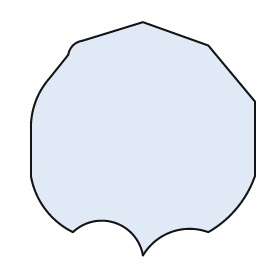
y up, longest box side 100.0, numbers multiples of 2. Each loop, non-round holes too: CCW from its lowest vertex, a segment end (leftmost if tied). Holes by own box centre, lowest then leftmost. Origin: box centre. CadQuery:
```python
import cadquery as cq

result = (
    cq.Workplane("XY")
    .moveTo(0.0, -50.0)
    .threePointArc((12.0, -40.0), (28.0, -40.0))
    .threePointArc((40.0, -30.0), (48.0, -16.0))
    .lineTo(48.0, 16.0)
    .lineTo(28.0, 40.0)
    .lineTo(0.0, 50.0)
    .lineTo(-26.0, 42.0)
    .threePointArc((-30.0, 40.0), (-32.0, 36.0))
    .lineTo(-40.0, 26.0)
    .threePointArc((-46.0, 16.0), (-48.0, 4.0))
    .lineTo(-48.0, -16.0)
    .threePointArc((-42.0, -30.0), (-30.0, -40.0))
    .threePointArc((-12.0, -36.0), (0.0, -50.0))
    .close()
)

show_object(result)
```